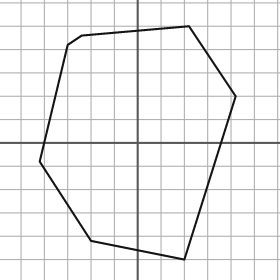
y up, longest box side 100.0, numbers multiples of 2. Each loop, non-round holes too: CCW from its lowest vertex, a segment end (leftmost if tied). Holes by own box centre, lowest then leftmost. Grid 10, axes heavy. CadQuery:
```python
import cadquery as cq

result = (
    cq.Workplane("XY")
    .moveTo(20.0, -50.0)
    .lineTo(42.0, 20.0)
    .lineTo(22.0, 50.0)
    .lineTo(-24.0, 46.0)
    .lineTo(-30.0, 42.0)
    .lineTo(-42.0, -8.0)
    .lineTo(-20.0, -42.0)
    .close()
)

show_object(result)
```